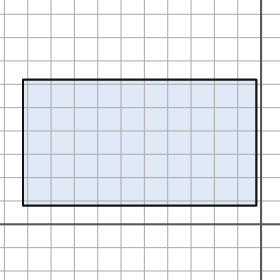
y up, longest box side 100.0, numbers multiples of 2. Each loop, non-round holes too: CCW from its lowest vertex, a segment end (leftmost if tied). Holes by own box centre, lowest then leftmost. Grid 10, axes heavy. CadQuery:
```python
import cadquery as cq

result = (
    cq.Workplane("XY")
    .moveTo(-102.0, 8.0)
    .lineTo(-2.0, 8.0)
    .lineTo(-2.0, 62.0)
    .lineTo(-102.0, 62.0)
    .close()
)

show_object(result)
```